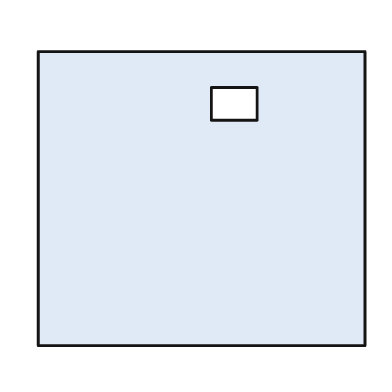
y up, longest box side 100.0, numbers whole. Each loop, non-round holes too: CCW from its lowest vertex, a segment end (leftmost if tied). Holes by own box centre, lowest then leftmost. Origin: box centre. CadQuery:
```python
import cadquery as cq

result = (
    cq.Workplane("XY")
    .moveTo(-50.0, -45.0)
    .lineTo(50.0, -45.0)
    .lineTo(50.0, 45.0)
    .lineTo(-50.0, 45.0)
    .close()
    .moveTo(3.0, 24.0)
    .lineTo(17.0, 24.0)
    .lineTo(17.0, 34.0)
    .lineTo(3.0, 34.0)
    .close()
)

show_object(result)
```